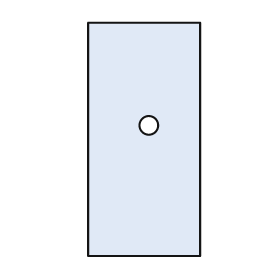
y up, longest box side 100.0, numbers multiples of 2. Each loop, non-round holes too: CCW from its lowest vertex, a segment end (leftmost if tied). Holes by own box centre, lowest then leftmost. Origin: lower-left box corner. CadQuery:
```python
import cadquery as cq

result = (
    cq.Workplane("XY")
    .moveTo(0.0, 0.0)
    .lineTo(48.0, 0.0)
    .lineTo(48.0, 100.0)
    .lineTo(0.0, 100.0)
    .close()
    .moveTo(26.0, 56.0)
    .circle(4.0)
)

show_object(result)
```